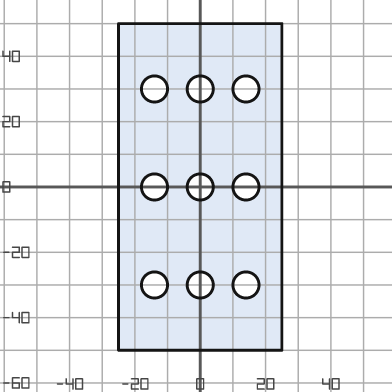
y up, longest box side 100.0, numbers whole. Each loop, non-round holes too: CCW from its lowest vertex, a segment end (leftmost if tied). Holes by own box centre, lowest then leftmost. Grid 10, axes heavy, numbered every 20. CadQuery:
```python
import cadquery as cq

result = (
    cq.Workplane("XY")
    .moveTo(-25.0, -50.0)
    .lineTo(25.0, -50.0)
    .lineTo(25.0, 50.0)
    .lineTo(-25.0, 50.0)
    .close()
    .moveTo(-14.0, -30.0)
    .circle(4.0)
    .moveTo(0.0, -30.0)
    .circle(4.0)
    .moveTo(14.0, -30.0)
    .circle(4.0)
    .moveTo(-14.0, 0.0)
    .circle(4.0)
    .moveTo(0.0, 0.0)
    .circle(4.0)
    .moveTo(14.0, 0.0)
    .circle(4.0)
    .moveTo(-14.0, 30.0)
    .circle(4.0)
    .moveTo(0.0, 30.0)
    .circle(4.0)
    .moveTo(14.0, 30.0)
    .circle(4.0)
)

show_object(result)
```